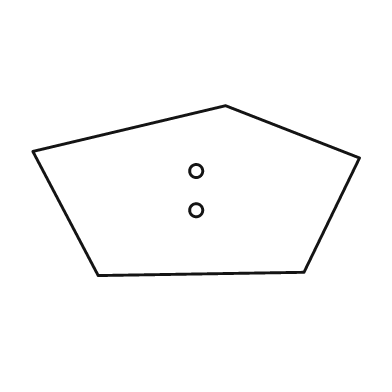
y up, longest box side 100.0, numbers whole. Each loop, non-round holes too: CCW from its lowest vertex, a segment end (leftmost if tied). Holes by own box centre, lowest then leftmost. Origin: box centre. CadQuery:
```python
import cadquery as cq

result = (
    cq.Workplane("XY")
    .moveTo(-30.0, -26.0)
    .lineTo(33.0, -25.0)
    .lineTo(50.0, 10.0)
    .lineTo(9.0, 26.0)
    .lineTo(-50.0, 12.0)
    .close()
    .moveTo(0.0, -6.0)
    .circle(2.0)
    .moveTo(0.0, 6.0)
    .circle(2.0)
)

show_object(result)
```